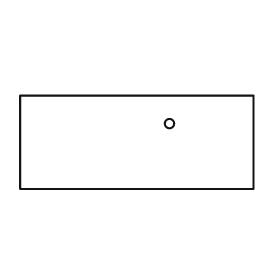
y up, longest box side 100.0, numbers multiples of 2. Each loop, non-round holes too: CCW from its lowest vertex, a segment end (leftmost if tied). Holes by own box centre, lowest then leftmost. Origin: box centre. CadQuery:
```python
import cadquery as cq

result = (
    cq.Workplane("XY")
    .moveTo(-50.0, -20.0)
    .lineTo(50.0, -20.0)
    .lineTo(50.0, 20.0)
    .lineTo(-50.0, 20.0)
    .close()
    .moveTo(14.0, 8.0)
    .circle(2.0)
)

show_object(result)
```